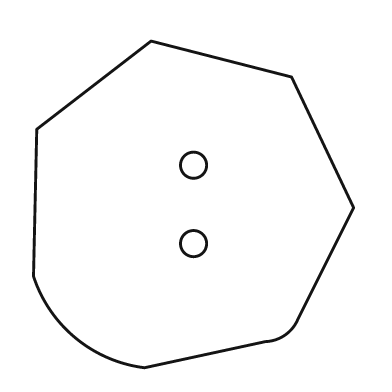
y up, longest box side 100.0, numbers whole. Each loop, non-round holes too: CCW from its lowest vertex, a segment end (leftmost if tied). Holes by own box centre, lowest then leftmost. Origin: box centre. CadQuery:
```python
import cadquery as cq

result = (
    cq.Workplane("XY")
    .moveTo(-15.0, -50.0)
    .lineTo(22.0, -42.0)
    .threePointArc((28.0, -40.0), (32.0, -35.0))
    .lineTo(49.0, -1.0)
    .lineTo(30.0, 39.0)
    .lineTo(-13.0, 50.0)
    .lineTo(-48.0, 23.0)
    .lineTo(-49.0, -22.0)
    .threePointArc((-36.0, -41.0), (-15.0, -50.0))
    .close()
    .moveTo(0.0, -12.0)
    .circle(4.0)
    .moveTo(0.0, 12.0)
    .circle(4.0)
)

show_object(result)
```